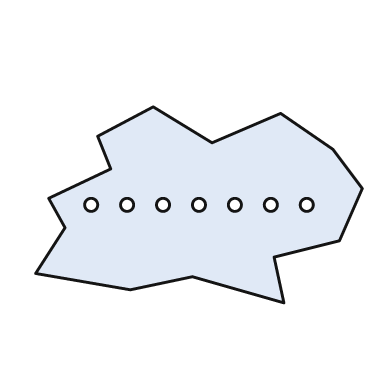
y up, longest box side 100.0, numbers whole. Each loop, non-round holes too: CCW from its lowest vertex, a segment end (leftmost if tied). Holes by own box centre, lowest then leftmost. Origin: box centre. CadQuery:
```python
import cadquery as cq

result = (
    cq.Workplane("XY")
    .moveTo(26.0, -30.0)
    .lineTo(23.0, -16.0)
    .lineTo(43.0, -11.0)
    .lineTo(50.0, 5.0)
    .lineTo(41.0, 17.0)
    .lineTo(25.0, 28.0)
    .lineTo(4.0, 19.0)
    .lineTo(-14.0, 30.0)
    .lineTo(-31.0, 21.0)
    .lineTo(-27.0, 11.0)
    .lineTo(-46.0, 2.0)
    .lineTo(-41.0, -7.0)
    .lineTo(-50.0, -21.0)
    .lineTo(-21.0, -26.0)
    .lineTo(-2.0, -22.0)
    .close()
    .moveTo(-33.0, 0.0)
    .circle(2.0)
    .moveTo(-22.0, 0.0)
    .circle(2.0)
    .moveTo(-11.0, 0.0)
    .circle(2.0)
    .moveTo(0.0, 0.0)
    .circle(2.0)
    .moveTo(11.0, 0.0)
    .circle(2.0)
    .moveTo(22.0, 0.0)
    .circle(2.0)
    .moveTo(33.0, 0.0)
    .circle(2.0)
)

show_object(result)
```